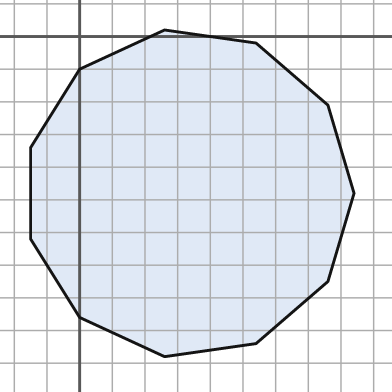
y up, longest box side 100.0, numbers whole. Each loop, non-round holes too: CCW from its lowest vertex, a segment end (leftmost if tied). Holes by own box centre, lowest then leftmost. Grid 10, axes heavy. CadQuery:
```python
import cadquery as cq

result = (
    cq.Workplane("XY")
    .moveTo(26.0, -98.0)
    .lineTo(54.0, -94.0)
    .lineTo(76.0, -75.0)
    .lineTo(84.0, -48.0)
    .lineTo(76.0, -21.0)
    .lineTo(54.0, -2.0)
    .lineTo(26.0, 2.0)
    .lineTo(0.0, -10.0)
    .lineTo(-15.0, -34.0)
    .lineTo(-15.0, -62.0)
    .lineTo(0.0, -86.0)
    .close()
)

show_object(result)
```